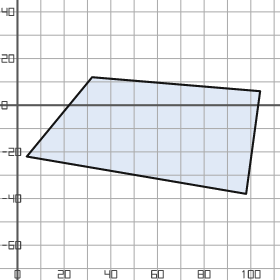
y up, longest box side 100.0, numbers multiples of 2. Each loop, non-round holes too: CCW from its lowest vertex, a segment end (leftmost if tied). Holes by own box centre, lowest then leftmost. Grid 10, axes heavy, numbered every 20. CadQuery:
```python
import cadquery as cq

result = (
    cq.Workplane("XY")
    .moveTo(98.0, -38.0)
    .lineTo(104.0, 6.0)
    .lineTo(32.0, 12.0)
    .lineTo(4.0, -22.0)
    .close()
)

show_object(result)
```